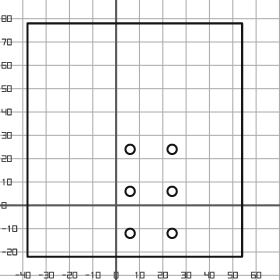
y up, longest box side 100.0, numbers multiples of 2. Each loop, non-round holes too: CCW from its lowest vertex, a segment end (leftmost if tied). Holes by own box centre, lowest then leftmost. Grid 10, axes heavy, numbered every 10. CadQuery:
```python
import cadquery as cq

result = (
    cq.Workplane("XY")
    .moveTo(-38.0, -22.0)
    .lineTo(54.0, -22.0)
    .lineTo(54.0, 78.0)
    .lineTo(-38.0, 78.0)
    .close()
    .moveTo(6.0, -12.0)
    .circle(2.0)
    .moveTo(24.0, -12.0)
    .circle(2.0)
    .moveTo(6.0, 6.0)
    .circle(2.0)
    .moveTo(24.0, 6.0)
    .circle(2.0)
    .moveTo(6.0, 24.0)
    .circle(2.0)
    .moveTo(24.0, 24.0)
    .circle(2.0)
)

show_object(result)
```